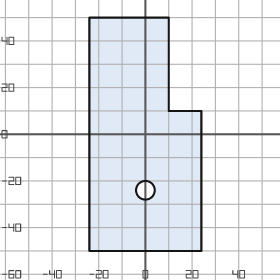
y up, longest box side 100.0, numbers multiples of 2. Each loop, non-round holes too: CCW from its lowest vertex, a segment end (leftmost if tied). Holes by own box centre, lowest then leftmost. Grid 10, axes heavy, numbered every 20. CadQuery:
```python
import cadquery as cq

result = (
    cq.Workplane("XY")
    .moveTo(-24.0, -50.0)
    .lineTo(24.0, -50.0)
    .lineTo(24.0, 10.0)
    .lineTo(10.0, 10.0)
    .lineTo(10.0, 50.0)
    .lineTo(-24.0, 50.0)
    .close()
    .moveTo(0.0, -24.0)
    .circle(4.0)
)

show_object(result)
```